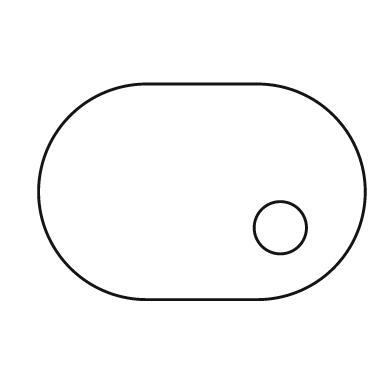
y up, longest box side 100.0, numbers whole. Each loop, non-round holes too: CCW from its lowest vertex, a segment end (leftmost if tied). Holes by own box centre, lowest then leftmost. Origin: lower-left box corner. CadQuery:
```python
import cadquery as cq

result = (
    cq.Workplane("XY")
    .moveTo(33.0, 0.0)
    .lineTo(67.0, 0.0)
    .threePointArc((100.0, 33.0), (67.0, 66.0))
    .lineTo(33.0, 66.0)
    .threePointArc((0.0, 33.0), (33.0, 0.0))
    .close()
    .moveTo(74.0, 22.0)
    .circle(8.0)
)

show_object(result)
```